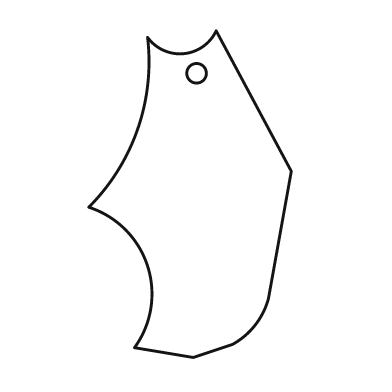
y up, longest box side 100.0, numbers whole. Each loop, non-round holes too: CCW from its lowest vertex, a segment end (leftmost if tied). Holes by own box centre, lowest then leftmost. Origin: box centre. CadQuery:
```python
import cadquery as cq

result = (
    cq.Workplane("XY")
    .moveTo(1.0, -50.0)
    .lineTo(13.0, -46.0)
    .threePointArc((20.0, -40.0), (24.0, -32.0))
    .lineTo(31.0, 7.0)
    .lineTo(8.0, 50.0)
    .threePointArc((-2.0, 43.0), (-13.0, 48.0))
    .threePointArc((-16.0, 20.0), (-31.0, -4.0))
    .threePointArc((-13.0, -22.0), (-17.0, -47.0))
    .close()
    .moveTo(2.0, 37.0)
    .circle(3.0)
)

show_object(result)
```